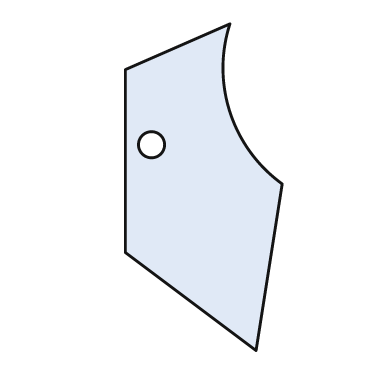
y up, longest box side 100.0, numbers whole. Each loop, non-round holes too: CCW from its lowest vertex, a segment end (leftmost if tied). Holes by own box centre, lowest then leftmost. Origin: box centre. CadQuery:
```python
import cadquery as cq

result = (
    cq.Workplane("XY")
    .moveTo(16.0, -50.0)
    .lineTo(24.0, 1.0)
    .threePointArc((8.0, 23.0), (8.0, 50.0))
    .lineTo(-24.0, 36.0)
    .lineTo(-24.0, -20.0)
    .close()
    .moveTo(-16.0, 13.0)
    .circle(4.0)
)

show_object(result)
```